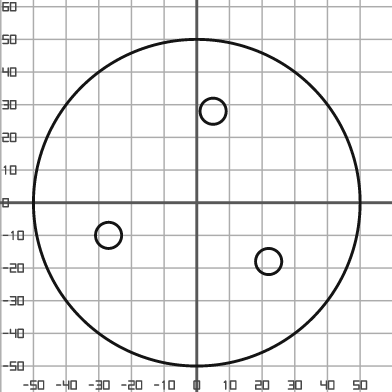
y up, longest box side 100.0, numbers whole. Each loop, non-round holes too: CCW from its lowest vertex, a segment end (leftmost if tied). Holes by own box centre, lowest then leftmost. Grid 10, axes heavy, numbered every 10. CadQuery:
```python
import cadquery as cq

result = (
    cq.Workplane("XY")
    .moveTo(0.0, 0.0)
    .circle(50.0)
    .moveTo(22.0, -18.0)
    .circle(4.0)
    .moveTo(-27.0, -10.0)
    .circle(4.0)
    .moveTo(5.0, 28.0)
    .circle(4.0)
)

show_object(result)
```